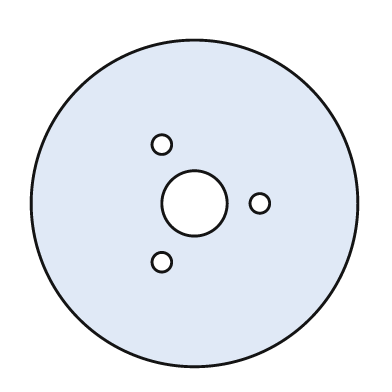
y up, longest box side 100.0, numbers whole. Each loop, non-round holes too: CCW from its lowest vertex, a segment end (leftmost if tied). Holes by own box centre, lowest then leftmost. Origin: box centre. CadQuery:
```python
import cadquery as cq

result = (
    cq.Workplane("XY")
    .moveTo(0.0, 0.0)
    .circle(50.0)
    .moveTo(-10.0, -18.0)
    .circle(3.0)
    .moveTo(0.0, 0.0)
    .circle(10.0)
    .moveTo(20.0, 0.0)
    .circle(3.0)
    .moveTo(-10.0, 18.0)
    .circle(3.0)
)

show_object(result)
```